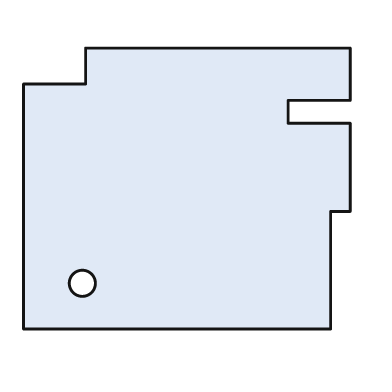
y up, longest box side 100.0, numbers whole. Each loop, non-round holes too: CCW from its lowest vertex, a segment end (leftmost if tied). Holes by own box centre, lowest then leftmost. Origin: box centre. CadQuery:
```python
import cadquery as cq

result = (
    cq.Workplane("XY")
    .moveTo(-50.0, -43.0)
    .lineTo(44.0, -43.0)
    .lineTo(44.0, -7.0)
    .lineTo(50.0, -7.0)
    .lineTo(50.0, 20.0)
    .lineTo(31.0, 20.0)
    .lineTo(31.0, 27.0)
    .lineTo(50.0, 27.0)
    .lineTo(50.0, 43.0)
    .lineTo(-31.0, 43.0)
    .lineTo(-31.0, 32.0)
    .lineTo(-50.0, 32.0)
    .close()
    .moveTo(-32.0, -29.0)
    .circle(4.0)
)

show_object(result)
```